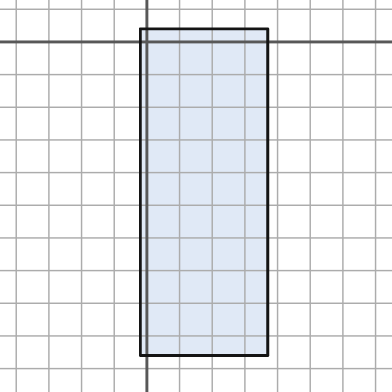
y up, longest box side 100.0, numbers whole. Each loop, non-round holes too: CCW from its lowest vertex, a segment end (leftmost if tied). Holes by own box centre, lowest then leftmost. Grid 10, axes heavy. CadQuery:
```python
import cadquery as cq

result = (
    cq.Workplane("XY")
    .moveTo(-2.0, -96.0)
    .lineTo(37.0, -96.0)
    .lineTo(37.0, 4.0)
    .lineTo(-2.0, 4.0)
    .close()
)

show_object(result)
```